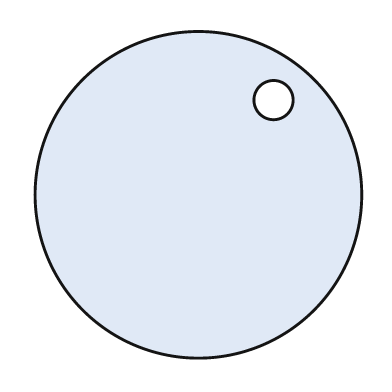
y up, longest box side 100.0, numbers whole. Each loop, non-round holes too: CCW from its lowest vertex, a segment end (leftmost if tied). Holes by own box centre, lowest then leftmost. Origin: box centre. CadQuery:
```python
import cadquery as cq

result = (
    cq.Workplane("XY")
    .moveTo(0.0, 0.0)
    .circle(50.0)
    .moveTo(23.0, 29.0)
    .circle(6.0)
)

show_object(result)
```